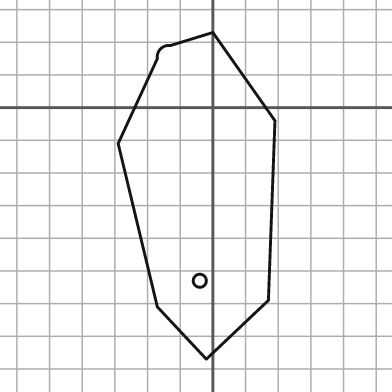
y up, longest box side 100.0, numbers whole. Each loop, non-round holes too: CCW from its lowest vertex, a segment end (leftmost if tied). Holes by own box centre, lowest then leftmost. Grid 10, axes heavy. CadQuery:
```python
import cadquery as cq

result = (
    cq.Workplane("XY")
    .moveTo(-2.0, -77.0)
    .lineTo(17.0, -59.0)
    .lineTo(19.0, -4.0)
    .lineTo(0.0, 23.0)
    .lineTo(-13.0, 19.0)
    .threePointArc((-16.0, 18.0), (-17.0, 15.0))
    .lineTo(-29.0, -11.0)
    .lineTo(-17.0, -61.0)
    .close()
    .moveTo(-4.0, -53.0)
    .circle(2.0)
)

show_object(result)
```